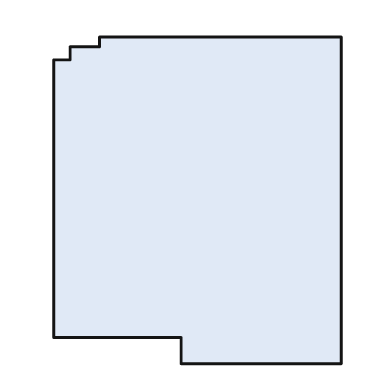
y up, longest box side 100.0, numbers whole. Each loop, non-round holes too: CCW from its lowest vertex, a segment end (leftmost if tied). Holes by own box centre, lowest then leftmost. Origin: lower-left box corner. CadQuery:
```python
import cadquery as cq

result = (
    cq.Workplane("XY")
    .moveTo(39.0, 0.0)
    .lineTo(88.0, 0.0)
    .lineTo(88.0, 100.0)
    .lineTo(14.0, 100.0)
    .lineTo(14.0, 97.0)
    .lineTo(5.0, 97.0)
    .lineTo(5.0, 93.0)
    .lineTo(0.0, 93.0)
    .lineTo(0.0, 8.0)
    .lineTo(39.0, 8.0)
    .close()
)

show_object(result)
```